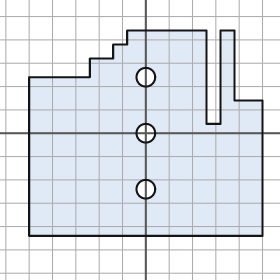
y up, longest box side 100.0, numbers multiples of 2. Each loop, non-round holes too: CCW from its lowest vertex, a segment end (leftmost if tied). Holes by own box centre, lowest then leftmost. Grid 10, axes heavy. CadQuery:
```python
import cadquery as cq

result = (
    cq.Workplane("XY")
    .moveTo(-50.0, -44.0)
    .lineTo(50.0, -44.0)
    .lineTo(50.0, 14.0)
    .lineTo(38.0, 14.0)
    .lineTo(38.0, 44.0)
    .lineTo(32.0, 44.0)
    .lineTo(32.0, 4.0)
    .lineTo(26.0, 4.0)
    .lineTo(26.0, 44.0)
    .lineTo(-8.0, 44.0)
    .lineTo(-8.0, 38.0)
    .lineTo(-14.0, 38.0)
    .lineTo(-14.0, 32.0)
    .lineTo(-24.0, 32.0)
    .lineTo(-24.0, 24.0)
    .lineTo(-50.0, 24.0)
    .close()
    .moveTo(0.0, -24.0)
    .circle(4.0)
    .moveTo(0.0, 0.0)
    .circle(4.0)
    .moveTo(0.0, 24.0)
    .circle(4.0)
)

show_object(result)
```